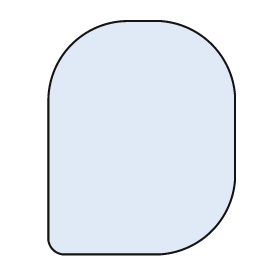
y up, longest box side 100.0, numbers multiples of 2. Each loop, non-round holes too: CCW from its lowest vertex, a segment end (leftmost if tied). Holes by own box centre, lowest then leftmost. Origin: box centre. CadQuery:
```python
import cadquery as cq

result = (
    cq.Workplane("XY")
    .moveTo(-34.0, -50.0)
    .lineTo(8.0, -50.0)
    .threePointArc((30.0, -40.0), (40.0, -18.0))
    .lineTo(40.0, 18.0)
    .threePointArc((30.0, 40.0), (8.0, 50.0))
    .lineTo(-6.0, 50.0)
    .threePointArc((-30.0, 40.0), (-40.0, 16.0))
    .lineTo(-40.0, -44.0)
    .threePointArc((-38.0, -48.0), (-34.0, -50.0))
    .close()
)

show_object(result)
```